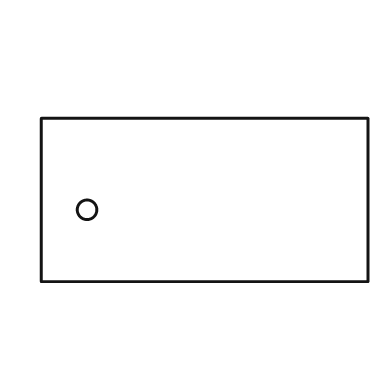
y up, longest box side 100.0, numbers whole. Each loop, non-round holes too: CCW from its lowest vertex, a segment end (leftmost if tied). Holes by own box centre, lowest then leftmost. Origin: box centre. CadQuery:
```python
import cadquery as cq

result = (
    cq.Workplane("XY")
    .moveTo(-50.0, -25.0)
    .lineTo(50.0, -25.0)
    .lineTo(50.0, 25.0)
    .lineTo(-50.0, 25.0)
    .close()
    .moveTo(-36.0, -3.0)
    .circle(3.0)
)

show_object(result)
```